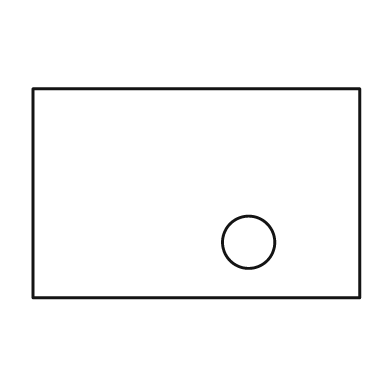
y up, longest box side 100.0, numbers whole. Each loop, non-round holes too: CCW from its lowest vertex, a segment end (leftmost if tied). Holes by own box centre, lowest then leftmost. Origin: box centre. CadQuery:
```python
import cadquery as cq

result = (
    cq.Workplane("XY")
    .moveTo(-50.0, -32.0)
    .lineTo(50.0, -32.0)
    .lineTo(50.0, 32.0)
    .lineTo(-50.0, 32.0)
    .close()
    .moveTo(16.0, -15.0)
    .circle(8.0)
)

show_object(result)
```